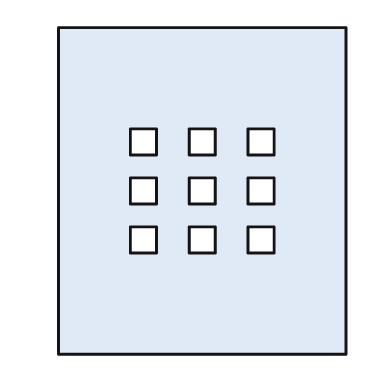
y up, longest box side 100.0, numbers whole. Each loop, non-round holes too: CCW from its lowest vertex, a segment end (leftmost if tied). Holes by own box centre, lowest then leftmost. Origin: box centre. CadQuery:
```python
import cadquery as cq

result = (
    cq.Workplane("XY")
    .moveTo(-44.0, -50.0)
    .lineTo(44.0, -50.0)
    .lineTo(44.0, 50.0)
    .lineTo(-44.0, 50.0)
    .close()
    .moveTo(-22.0, -19.0)
    .lineTo(-14.0, -19.0)
    .lineTo(-14.0, -11.0)
    .lineTo(-22.0, -11.0)
    .close()
    .moveTo(-4.0, -19.0)
    .lineTo(4.0, -19.0)
    .lineTo(4.0, -11.0)
    .lineTo(-4.0, -11.0)
    .close()
    .moveTo(14.0, -19.0)
    .lineTo(22.0, -19.0)
    .lineTo(22.0, -11.0)
    .lineTo(14.0, -11.0)
    .close()
    .moveTo(-22.0, -4.0)
    .lineTo(-14.0, -4.0)
    .lineTo(-14.0, 4.0)
    .lineTo(-22.0, 4.0)
    .close()
    .moveTo(-4.0, -4.0)
    .lineTo(4.0, -4.0)
    .lineTo(4.0, 4.0)
    .lineTo(-4.0, 4.0)
    .close()
    .moveTo(14.0, -4.0)
    .lineTo(22.0, -4.0)
    .lineTo(22.0, 4.0)
    .lineTo(14.0, 4.0)
    .close()
    .moveTo(-22.0, 11.0)
    .lineTo(-14.0, 11.0)
    .lineTo(-14.0, 19.0)
    .lineTo(-22.0, 19.0)
    .close()
    .moveTo(-4.0, 11.0)
    .lineTo(4.0, 11.0)
    .lineTo(4.0, 19.0)
    .lineTo(-4.0, 19.0)
    .close()
    .moveTo(14.0, 11.0)
    .lineTo(22.0, 11.0)
    .lineTo(22.0, 19.0)
    .lineTo(14.0, 19.0)
    .close()
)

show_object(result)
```